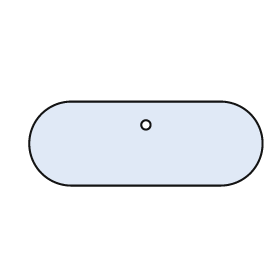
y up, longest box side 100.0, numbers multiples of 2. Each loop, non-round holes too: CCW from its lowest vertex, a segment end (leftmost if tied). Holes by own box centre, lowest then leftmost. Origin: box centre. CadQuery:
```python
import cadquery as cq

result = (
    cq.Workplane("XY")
    .moveTo(-32.0, -18.0)
    .lineTo(32.0, -18.0)
    .threePointArc((50.0, 0.0), (32.0, 18.0))
    .lineTo(-32.0, 18.0)
    .threePointArc((-50.0, 0.0), (-32.0, -18.0))
    .close()
    .moveTo(0.0, 8.0)
    .circle(2.0)
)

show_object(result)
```